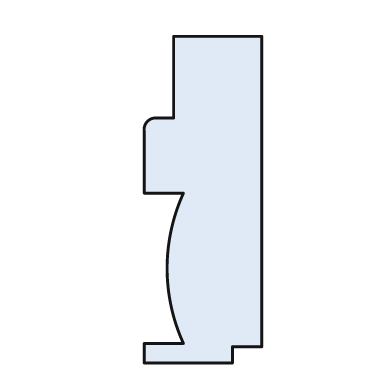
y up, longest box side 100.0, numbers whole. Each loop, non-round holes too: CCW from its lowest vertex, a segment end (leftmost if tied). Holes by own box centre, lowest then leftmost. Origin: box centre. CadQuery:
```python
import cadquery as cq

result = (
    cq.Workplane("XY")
    .moveTo(-18.0, -50.0)
    .lineTo(9.0, -50.0)
    .lineTo(9.0, -45.0)
    .lineTo(18.0, -45.0)
    .lineTo(18.0, 50.0)
    .lineTo(-9.0, 50.0)
    .lineTo(-9.0, 25.0)
    .lineTo(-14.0, 25.0)
    .threePointArc((-17.0, 24.0), (-18.0, 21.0))
    .lineTo(-18.0, 2.0)
    .lineTo(-6.0, 2.0)
    .threePointArc((-11.0, -21.0), (-6.0, -44.0))
    .lineTo(-18.0, -44.0)
    .close()
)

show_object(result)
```